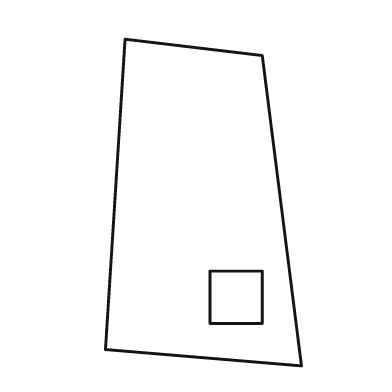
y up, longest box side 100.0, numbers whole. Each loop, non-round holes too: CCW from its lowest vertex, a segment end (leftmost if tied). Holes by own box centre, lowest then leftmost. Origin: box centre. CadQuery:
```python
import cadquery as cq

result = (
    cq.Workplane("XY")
    .moveTo(30.0, -50.0)
    .lineTo(18.0, 45.0)
    .lineTo(-24.0, 50.0)
    .lineTo(-30.0, -45.0)
    .close()
    .moveTo(2.0, -37.0)
    .lineTo(18.0, -37.0)
    .lineTo(18.0, -21.0)
    .lineTo(2.0, -21.0)
    .close()
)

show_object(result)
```